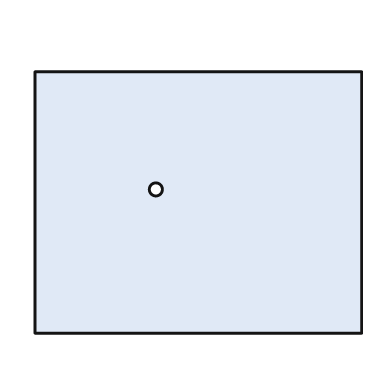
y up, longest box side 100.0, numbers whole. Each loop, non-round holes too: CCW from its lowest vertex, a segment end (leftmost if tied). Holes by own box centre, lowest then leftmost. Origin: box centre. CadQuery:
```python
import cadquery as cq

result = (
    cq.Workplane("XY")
    .moveTo(-50.0, -40.0)
    .lineTo(50.0, -40.0)
    .lineTo(50.0, 40.0)
    .lineTo(-50.0, 40.0)
    .close()
    .moveTo(-13.0, 4.0)
    .circle(2.0)
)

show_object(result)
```